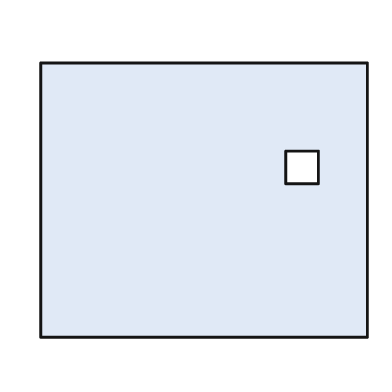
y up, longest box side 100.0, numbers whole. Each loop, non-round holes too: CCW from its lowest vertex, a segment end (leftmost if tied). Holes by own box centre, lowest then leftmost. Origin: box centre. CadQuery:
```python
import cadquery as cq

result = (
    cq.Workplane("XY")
    .moveTo(-50.0, -42.0)
    .lineTo(50.0, -42.0)
    .lineTo(50.0, 42.0)
    .lineTo(-50.0, 42.0)
    .close()
    .moveTo(25.0, 5.0)
    .lineTo(35.0, 5.0)
    .lineTo(35.0, 15.0)
    .lineTo(25.0, 15.0)
    .close()
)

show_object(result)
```